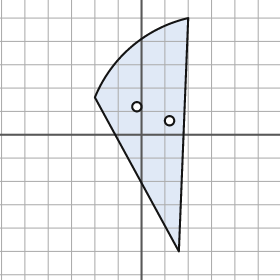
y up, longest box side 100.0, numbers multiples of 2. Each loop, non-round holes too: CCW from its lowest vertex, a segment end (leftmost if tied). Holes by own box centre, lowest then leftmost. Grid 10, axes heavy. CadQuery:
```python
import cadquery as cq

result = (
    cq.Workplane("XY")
    .moveTo(16.0, -50.0)
    .lineTo(20.0, 50.0)
    .threePointArc((-4.0, 38.0), (-20.0, 16.0))
    .close()
    .moveTo(12.0, 6.0)
    .circle(2.0)
    .moveTo(-2.0, 12.0)
    .circle(2.0)
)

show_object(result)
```